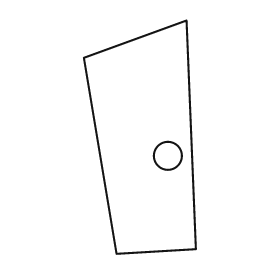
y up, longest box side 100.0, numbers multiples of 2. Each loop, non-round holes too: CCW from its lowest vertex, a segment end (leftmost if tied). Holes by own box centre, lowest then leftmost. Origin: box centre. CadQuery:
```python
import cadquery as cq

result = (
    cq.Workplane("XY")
    .moveTo(-10.0, -50.0)
    .lineTo(24.0, -48.0)
    .lineTo(20.0, 50.0)
    .lineTo(-24.0, 34.0)
    .close()
    .moveTo(12.0, -8.0)
    .circle(6.0)
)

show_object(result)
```